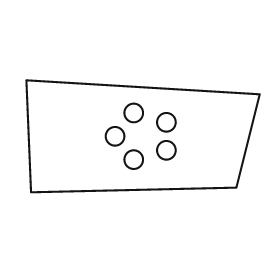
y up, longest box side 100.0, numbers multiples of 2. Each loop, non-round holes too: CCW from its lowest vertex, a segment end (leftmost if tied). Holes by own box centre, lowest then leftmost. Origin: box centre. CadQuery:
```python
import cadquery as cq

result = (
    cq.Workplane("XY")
    .moveTo(-48.0, -24.0)
    .lineTo(40.0, -22.0)
    .lineTo(50.0, 18.0)
    .lineTo(-50.0, 24.0)
    .close()
    .moveTo(-4.0, -10.0)
    .circle(4.0)
    .moveTo(10.0, -6.0)
    .circle(4.0)
    .moveTo(-12.0, 0.0)
    .circle(4.0)
    .moveTo(10.0, 6.0)
    .circle(4.0)
    .moveTo(-4.0, 10.0)
    .circle(4.0)
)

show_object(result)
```